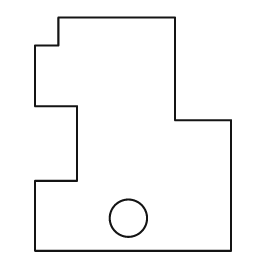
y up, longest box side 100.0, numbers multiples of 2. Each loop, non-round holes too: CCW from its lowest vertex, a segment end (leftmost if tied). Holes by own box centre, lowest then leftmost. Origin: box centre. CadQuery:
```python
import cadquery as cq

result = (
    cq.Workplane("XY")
    .moveTo(-42.0, -50.0)
    .lineTo(42.0, -50.0)
    .lineTo(42.0, 6.0)
    .lineTo(18.0, 6.0)
    .lineTo(18.0, 50.0)
    .lineTo(-32.0, 50.0)
    .lineTo(-32.0, 38.0)
    .lineTo(-42.0, 38.0)
    .lineTo(-42.0, 12.0)
    .lineTo(-24.0, 12.0)
    .lineTo(-24.0, -20.0)
    .lineTo(-42.0, -20.0)
    .close()
    .moveTo(-2.0, -36.0)
    .circle(8.0)
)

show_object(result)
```